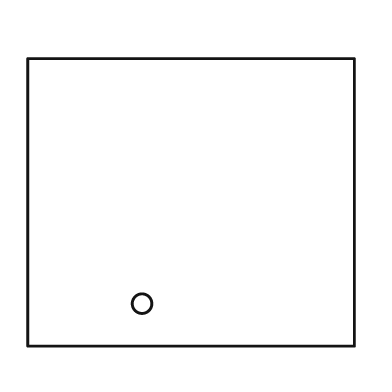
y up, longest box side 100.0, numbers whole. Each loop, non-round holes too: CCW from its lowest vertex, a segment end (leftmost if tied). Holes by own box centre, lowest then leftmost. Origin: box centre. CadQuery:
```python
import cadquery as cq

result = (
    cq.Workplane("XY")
    .moveTo(-50.0, -44.0)
    .lineTo(50.0, -44.0)
    .lineTo(50.0, 44.0)
    .lineTo(-50.0, 44.0)
    .close()
    .moveTo(-15.0, -31.0)
    .circle(3.0)
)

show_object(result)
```